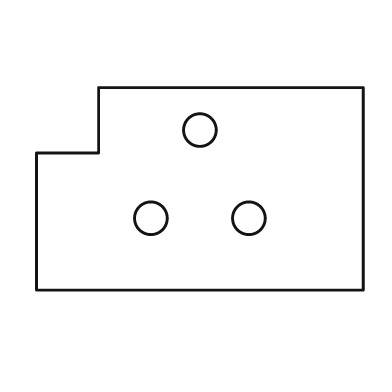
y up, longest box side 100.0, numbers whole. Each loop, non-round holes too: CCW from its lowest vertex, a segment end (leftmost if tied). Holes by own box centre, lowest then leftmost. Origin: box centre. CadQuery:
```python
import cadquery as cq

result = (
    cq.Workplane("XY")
    .moveTo(-50.0, -31.0)
    .lineTo(50.0, -31.0)
    .lineTo(50.0, 31.0)
    .lineTo(-31.0, 31.0)
    .lineTo(-31.0, 11.0)
    .lineTo(-50.0, 11.0)
    .close()
    .moveTo(-15.0, -9.0)
    .circle(5.0)
    .moveTo(15.0, -9.0)
    .circle(5.0)
    .moveTo(0.0, 18.0)
    .circle(5.0)
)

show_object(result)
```